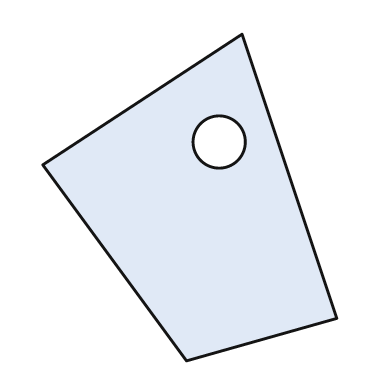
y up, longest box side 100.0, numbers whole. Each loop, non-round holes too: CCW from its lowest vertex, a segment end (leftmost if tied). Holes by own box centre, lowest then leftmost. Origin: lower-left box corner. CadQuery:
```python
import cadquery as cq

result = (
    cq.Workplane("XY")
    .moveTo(44.0, 0.0)
    .lineTo(90.0, 13.0)
    .lineTo(61.0, 100.0)
    .lineTo(0.0, 60.0)
    .close()
    .moveTo(54.0, 67.0)
    .circle(8.0)
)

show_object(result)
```